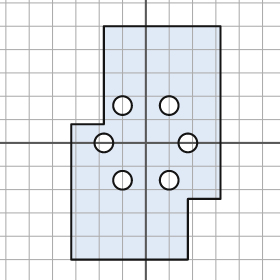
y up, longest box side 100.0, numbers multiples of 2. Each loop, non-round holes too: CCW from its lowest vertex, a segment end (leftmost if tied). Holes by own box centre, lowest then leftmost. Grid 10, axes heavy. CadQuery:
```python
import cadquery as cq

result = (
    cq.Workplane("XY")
    .moveTo(-32.0, -50.0)
    .lineTo(18.0, -50.0)
    .lineTo(18.0, -24.0)
    .lineTo(32.0, -24.0)
    .lineTo(32.0, 50.0)
    .lineTo(-18.0, 50.0)
    .lineTo(-18.0, 8.0)
    .lineTo(-32.0, 8.0)
    .close()
    .moveTo(-10.0, -16.0)
    .circle(4.0)
    .moveTo(10.0, -16.0)
    .circle(4.0)
    .moveTo(-18.0, 0.0)
    .circle(4.0)
    .moveTo(18.0, 0.0)
    .circle(4.0)
    .moveTo(-10.0, 16.0)
    .circle(4.0)
    .moveTo(10.0, 16.0)
    .circle(4.0)
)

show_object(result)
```